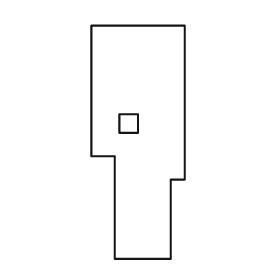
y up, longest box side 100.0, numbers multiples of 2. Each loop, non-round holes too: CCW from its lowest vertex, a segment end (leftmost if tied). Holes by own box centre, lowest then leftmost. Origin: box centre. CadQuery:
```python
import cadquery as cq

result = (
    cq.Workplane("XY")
    .moveTo(-10.0, -50.0)
    .lineTo(14.0, -50.0)
    .lineTo(14.0, -16.0)
    .lineTo(20.0, -16.0)
    .lineTo(20.0, 50.0)
    .lineTo(-20.0, 50.0)
    .lineTo(-20.0, -6.0)
    .lineTo(-10.0, -6.0)
    .close()
    .moveTo(-8.0, 4.0)
    .lineTo(0.0, 4.0)
    .lineTo(0.0, 12.0)
    .lineTo(-8.0, 12.0)
    .close()
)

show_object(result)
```